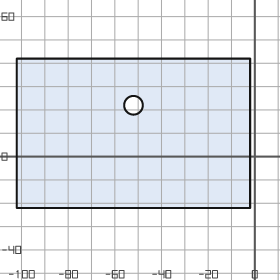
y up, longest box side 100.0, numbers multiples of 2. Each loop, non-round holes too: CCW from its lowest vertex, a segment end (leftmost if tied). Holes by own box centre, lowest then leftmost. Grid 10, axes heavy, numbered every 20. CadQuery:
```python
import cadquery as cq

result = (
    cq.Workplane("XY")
    .moveTo(-102.0, -22.0)
    .lineTo(-2.0, -22.0)
    .lineTo(-2.0, 42.0)
    .lineTo(-102.0, 42.0)
    .close()
    .moveTo(-52.0, 22.0)
    .circle(4.0)
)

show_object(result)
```